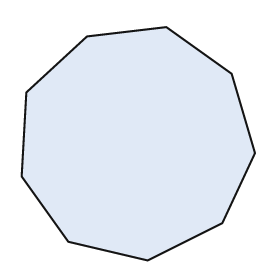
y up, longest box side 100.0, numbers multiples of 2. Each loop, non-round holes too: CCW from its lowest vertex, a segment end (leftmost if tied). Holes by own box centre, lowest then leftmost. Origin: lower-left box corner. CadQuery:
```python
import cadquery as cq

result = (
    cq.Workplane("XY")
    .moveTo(54.0, 0.0)
    .lineTo(86.0, 16.0)
    .lineTo(100.0, 46.0)
    .lineTo(90.0, 80.0)
    .lineTo(62.0, 100.0)
    .lineTo(28.0, 96.0)
    .lineTo(2.0, 72.0)
    .lineTo(0.0, 36.0)
    .lineTo(20.0, 8.0)
    .close()
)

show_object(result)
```